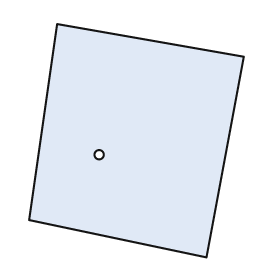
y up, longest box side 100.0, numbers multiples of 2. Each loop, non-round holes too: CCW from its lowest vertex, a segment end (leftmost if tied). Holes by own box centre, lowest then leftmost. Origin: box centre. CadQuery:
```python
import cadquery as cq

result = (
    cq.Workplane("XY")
    .moveTo(30.0, -50.0)
    .lineTo(46.0, 36.0)
    .lineTo(-34.0, 50.0)
    .lineTo(-46.0, -34.0)
    .close()
    .moveTo(-16.0, -6.0)
    .circle(2.0)
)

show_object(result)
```